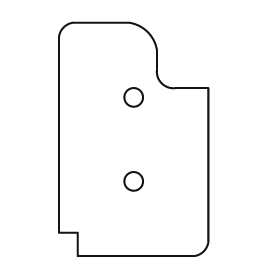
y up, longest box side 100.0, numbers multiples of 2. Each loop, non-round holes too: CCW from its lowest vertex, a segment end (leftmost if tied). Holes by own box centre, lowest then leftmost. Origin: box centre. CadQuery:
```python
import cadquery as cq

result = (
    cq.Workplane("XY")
    .moveTo(-24.0, -50.0)
    .lineTo(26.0, -50.0)
    .threePointArc((30.0, -48.0), (32.0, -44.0))
    .lineTo(32.0, 22.0)
    .lineTo(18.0, 22.0)
    .threePointArc((12.0, 24.0), (10.0, 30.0))
    .lineTo(10.0, 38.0)
    .threePointArc((6.0, 46.0), (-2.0, 50.0))
    .lineTo(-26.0, 50.0)
    .threePointArc((-30.0, 48.0), (-32.0, 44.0))
    .lineTo(-32.0, -40.0)
    .lineTo(-24.0, -40.0)
    .close()
    .moveTo(0.0, -18.0)
    .circle(4.0)
    .moveTo(0.0, 18.0)
    .circle(4.0)
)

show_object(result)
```